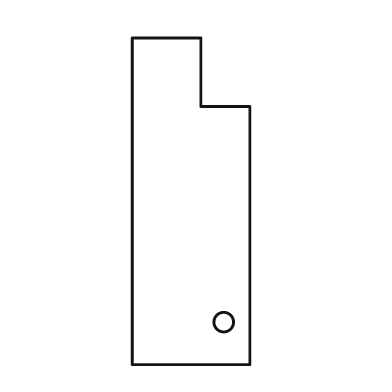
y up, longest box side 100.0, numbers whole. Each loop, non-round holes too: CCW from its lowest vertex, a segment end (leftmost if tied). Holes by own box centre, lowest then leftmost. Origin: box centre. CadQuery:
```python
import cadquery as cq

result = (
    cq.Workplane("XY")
    .moveTo(-18.0, -50.0)
    .lineTo(18.0, -50.0)
    .lineTo(18.0, 29.0)
    .lineTo(3.0, 29.0)
    .lineTo(3.0, 50.0)
    .lineTo(-18.0, 50.0)
    .close()
    .moveTo(10.0, -37.0)
    .circle(3.0)
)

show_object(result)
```